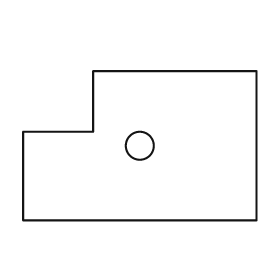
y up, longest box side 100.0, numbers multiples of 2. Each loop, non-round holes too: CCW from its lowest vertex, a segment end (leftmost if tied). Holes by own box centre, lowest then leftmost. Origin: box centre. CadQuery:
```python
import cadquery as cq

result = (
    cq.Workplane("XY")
    .moveTo(-50.0, -32.0)
    .lineTo(50.0, -32.0)
    .lineTo(50.0, 32.0)
    .lineTo(-20.0, 32.0)
    .lineTo(-20.0, 6.0)
    .lineTo(-50.0, 6.0)
    .close()
    .moveTo(0.0, 0.0)
    .circle(6.0)
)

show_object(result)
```